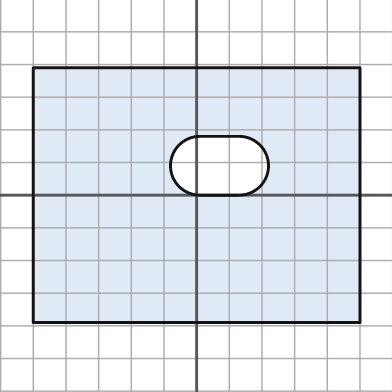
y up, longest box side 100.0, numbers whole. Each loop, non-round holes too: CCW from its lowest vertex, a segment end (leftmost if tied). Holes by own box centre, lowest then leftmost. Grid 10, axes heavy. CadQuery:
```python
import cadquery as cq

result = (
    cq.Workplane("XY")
    .moveTo(-50.0, -39.0)
    .lineTo(50.0, -39.0)
    .lineTo(50.0, 39.0)
    .lineTo(-50.0, 39.0)
    .close()
    .moveTo(1.0, 0.0)
    .lineTo(13.0, 0.0)
    .threePointArc((22.0, 9.0), (13.0, 18.0))
    .lineTo(1.0, 18.0)
    .threePointArc((-8.0, 9.0), (1.0, 0.0))
    .close()
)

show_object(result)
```